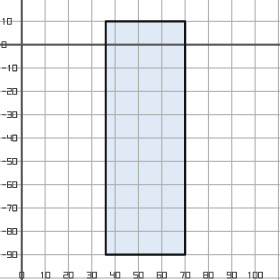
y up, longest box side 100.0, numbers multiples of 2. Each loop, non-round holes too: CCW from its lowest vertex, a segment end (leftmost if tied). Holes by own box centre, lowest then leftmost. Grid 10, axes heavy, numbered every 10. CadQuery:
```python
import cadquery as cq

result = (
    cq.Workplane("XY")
    .moveTo(36.0, -90.0)
    .lineTo(70.0, -90.0)
    .lineTo(70.0, 10.0)
    .lineTo(36.0, 10.0)
    .close()
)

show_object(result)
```